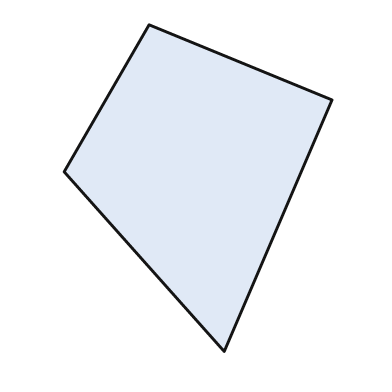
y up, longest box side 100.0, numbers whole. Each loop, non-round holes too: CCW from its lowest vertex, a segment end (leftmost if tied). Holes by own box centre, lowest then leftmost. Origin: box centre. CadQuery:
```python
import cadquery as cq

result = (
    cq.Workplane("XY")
    .moveTo(8.0, -50.0)
    .lineTo(41.0, 27.0)
    .lineTo(-15.0, 50.0)
    .lineTo(-41.0, 5.0)
    .close()
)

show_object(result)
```